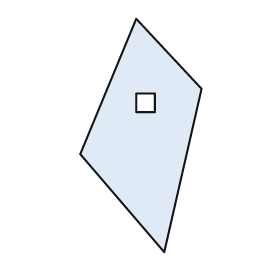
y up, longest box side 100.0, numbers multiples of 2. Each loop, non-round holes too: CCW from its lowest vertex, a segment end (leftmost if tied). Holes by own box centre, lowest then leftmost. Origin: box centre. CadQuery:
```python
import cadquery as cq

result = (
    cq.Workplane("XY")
    .moveTo(10.0, -50.0)
    .lineTo(26.0, 20.0)
    .lineTo(-2.0, 50.0)
    .lineTo(-26.0, -8.0)
    .close()
    .moveTo(-2.0, 10.0)
    .lineTo(6.0, 10.0)
    .lineTo(6.0, 18.0)
    .lineTo(-2.0, 18.0)
    .close()
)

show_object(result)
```